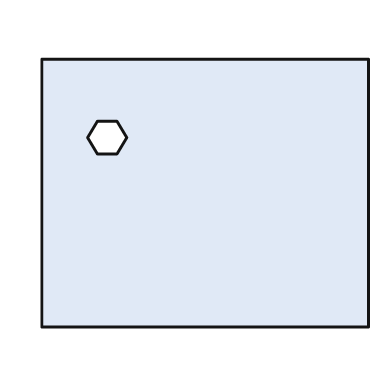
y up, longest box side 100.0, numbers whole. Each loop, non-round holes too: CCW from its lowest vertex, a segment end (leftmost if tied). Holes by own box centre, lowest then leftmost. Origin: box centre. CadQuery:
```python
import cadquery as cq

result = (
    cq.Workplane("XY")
    .moveTo(-50.0, -41.0)
    .lineTo(50.0, -41.0)
    .lineTo(50.0, 41.0)
    .lineTo(-50.0, 41.0)
    .close()
    .moveTo(-33.0, 12.0)
    .lineTo(-27.0, 12.0)
    .lineTo(-24.0, 17.0)
    .lineTo(-27.0, 22.0)
    .lineTo(-33.0, 22.0)
    .lineTo(-36.0, 17.0)
    .close()
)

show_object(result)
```